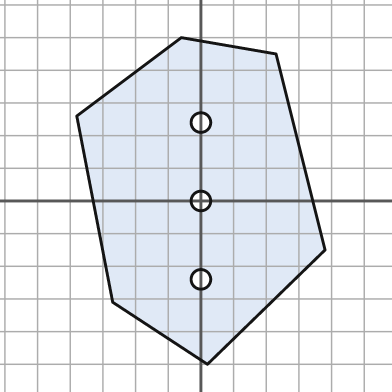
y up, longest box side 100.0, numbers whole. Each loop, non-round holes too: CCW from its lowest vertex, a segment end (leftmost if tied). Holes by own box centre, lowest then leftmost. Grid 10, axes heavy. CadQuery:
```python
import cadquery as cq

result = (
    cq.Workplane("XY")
    .moveTo(2.0, -50.0)
    .lineTo(38.0, -15.0)
    .lineTo(23.0, 45.0)
    .lineTo(-6.0, 50.0)
    .lineTo(-38.0, 26.0)
    .lineTo(-27.0, -31.0)
    .close()
    .moveTo(0.0, -24.0)
    .circle(3.0)
    .moveTo(0.0, 0.0)
    .circle(3.0)
    .moveTo(0.0, 24.0)
    .circle(3.0)
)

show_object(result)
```